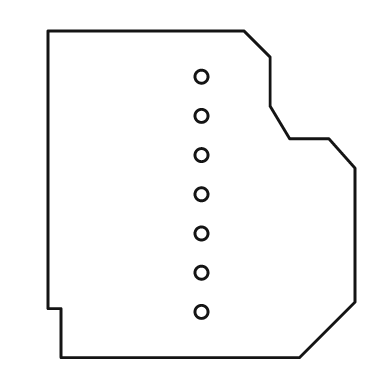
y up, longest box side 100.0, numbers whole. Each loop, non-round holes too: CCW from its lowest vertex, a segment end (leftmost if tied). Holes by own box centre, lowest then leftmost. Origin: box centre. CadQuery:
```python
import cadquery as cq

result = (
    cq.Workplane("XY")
    .moveTo(-43.0, -50.0)
    .lineTo(30.0, -50.0)
    .lineTo(47.0, -33.0)
    .lineTo(47.0, 8.0)
    .lineTo(39.0, 17.0)
    .lineTo(27.0, 17.0)
    .lineTo(21.0, 27.0)
    .lineTo(21.0, 42.0)
    .lineTo(13.0, 50.0)
    .lineTo(-47.0, 50.0)
    .lineTo(-47.0, -35.0)
    .lineTo(-43.0, -35.0)
    .close()
    .moveTo(0.0, -36.0)
    .circle(2.0)
    .moveTo(0.0, -24.0)
    .circle(2.0)
    .moveTo(0.0, -12.0)
    .circle(2.0)
    .moveTo(0.0, 0.0)
    .circle(2.0)
    .moveTo(0.0, 12.0)
    .circle(2.0)
    .moveTo(0.0, 24.0)
    .circle(2.0)
    .moveTo(0.0, 36.0)
    .circle(2.0)
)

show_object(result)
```